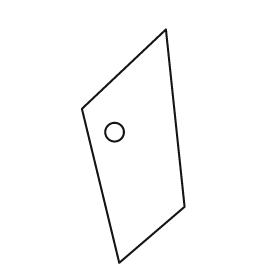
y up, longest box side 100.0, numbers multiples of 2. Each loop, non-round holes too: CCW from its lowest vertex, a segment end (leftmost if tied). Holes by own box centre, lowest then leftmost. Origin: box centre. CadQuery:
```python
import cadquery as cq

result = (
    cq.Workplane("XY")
    .moveTo(-6.0, -50.0)
    .lineTo(22.0, -26.0)
    .lineTo(14.0, 50.0)
    .lineTo(-22.0, 16.0)
    .close()
    .moveTo(-8.0, 6.0)
    .circle(4.0)
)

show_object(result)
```